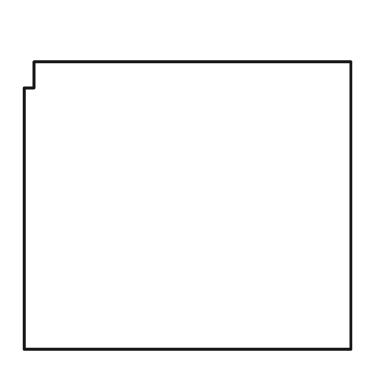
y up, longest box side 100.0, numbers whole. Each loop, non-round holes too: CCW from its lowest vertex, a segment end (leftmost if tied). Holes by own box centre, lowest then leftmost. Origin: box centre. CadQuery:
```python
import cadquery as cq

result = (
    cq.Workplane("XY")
    .moveTo(-50.0, -44.0)
    .lineTo(50.0, -44.0)
    .lineTo(50.0, 44.0)
    .lineTo(-47.0, 44.0)
    .lineTo(-47.0, 36.0)
    .lineTo(-50.0, 36.0)
    .close()
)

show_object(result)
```